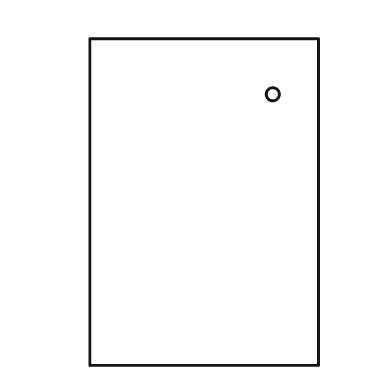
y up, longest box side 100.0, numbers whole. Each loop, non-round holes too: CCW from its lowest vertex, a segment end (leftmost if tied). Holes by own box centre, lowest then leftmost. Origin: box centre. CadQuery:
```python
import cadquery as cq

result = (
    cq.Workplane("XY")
    .moveTo(-35.0, -50.0)
    .lineTo(35.0, -50.0)
    .lineTo(35.0, 50.0)
    .lineTo(-35.0, 50.0)
    .close()
    .moveTo(21.0, 33.0)
    .circle(2.0)
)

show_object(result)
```